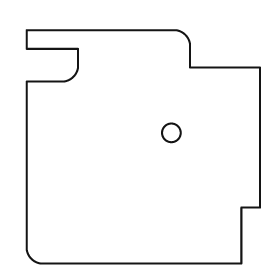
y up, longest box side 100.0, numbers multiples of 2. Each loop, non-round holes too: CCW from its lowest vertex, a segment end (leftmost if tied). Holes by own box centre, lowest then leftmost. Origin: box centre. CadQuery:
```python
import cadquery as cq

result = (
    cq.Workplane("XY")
    .moveTo(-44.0, -50.0)
    .lineTo(42.0, -50.0)
    .lineTo(42.0, -26.0)
    .lineTo(50.0, -26.0)
    .lineTo(50.0, 34.0)
    .lineTo(20.0, 34.0)
    .lineTo(20.0, 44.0)
    .threePointArc((18.0, 48.0), (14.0, 50.0))
    .lineTo(-50.0, 50.0)
    .lineTo(-50.0, 42.0)
    .lineTo(-28.0, 42.0)
    .lineTo(-28.0, 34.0)
    .threePointArc((-30.0, 30.0), (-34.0, 28.0))
    .lineTo(-50.0, 28.0)
    .lineTo(-50.0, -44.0)
    .threePointArc((-48.0, -48.0), (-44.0, -50.0))
    .close()
    .moveTo(12.0, 6.0)
    .circle(4.0)
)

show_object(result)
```